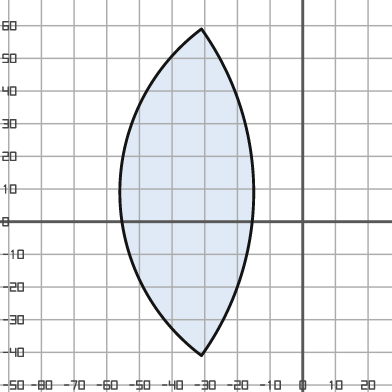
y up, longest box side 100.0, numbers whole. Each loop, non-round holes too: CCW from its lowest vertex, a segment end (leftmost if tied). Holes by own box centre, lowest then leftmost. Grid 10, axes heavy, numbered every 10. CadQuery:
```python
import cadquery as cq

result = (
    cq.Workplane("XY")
    .moveTo(-31.0, -41.0)
    .threePointArc((-15.0, 9.0), (-31.0, 59.0))
    .threePointArc((-56.0, 9.0), (-31.0, -41.0))
    .close()
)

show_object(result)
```